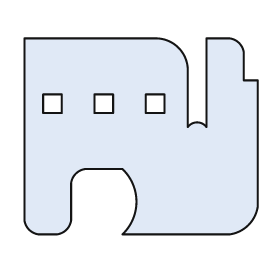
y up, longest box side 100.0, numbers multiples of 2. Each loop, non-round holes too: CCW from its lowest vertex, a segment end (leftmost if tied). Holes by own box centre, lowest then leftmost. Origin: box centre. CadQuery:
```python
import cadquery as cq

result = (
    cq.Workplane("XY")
    .moveTo(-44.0, -42.0)
    .lineTo(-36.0, -42.0)
    .threePointArc((-32.0, -40.0), (-30.0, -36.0))
    .lineTo(-30.0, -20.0)
    .threePointArc((-28.0, -16.0), (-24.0, -14.0))
    .lineTo(-8.0, -14.0)
    .threePointArc((-2.0, -28.0), (-8.0, -42.0))
    .lineTo(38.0, -42.0)
    .threePointArc((46.0, -38.0), (50.0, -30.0))
    .lineTo(50.0, 24.0)
    .lineTo(44.0, 24.0)
    .lineTo(44.0, 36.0)
    .threePointArc((42.0, 40.0), (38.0, 42.0))
    .lineTo(28.0, 42.0)
    .lineTo(28.0, 4.0)
    .threePointArc((24.0, 6.0), (20.0, 4.0))
    .lineTo(20.0, 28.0)
    .threePointArc((16.0, 38.0), (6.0, 42.0))
    .lineTo(-50.0, 42.0)
    .lineTo(-50.0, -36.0)
    .threePointArc((-48.0, -40.0), (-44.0, -42.0))
    .close()
    .moveTo(-42.0, 10.0)
    .lineTo(-34.0, 10.0)
    .lineTo(-34.0, 18.0)
    .lineTo(-42.0, 18.0)
    .close()
    .moveTo(-20.0, 10.0)
    .lineTo(-12.0, 10.0)
    .lineTo(-12.0, 18.0)
    .lineTo(-20.0, 18.0)
    .close()
    .moveTo(2.0, 10.0)
    .lineTo(10.0, 10.0)
    .lineTo(10.0, 18.0)
    .lineTo(2.0, 18.0)
    .close()
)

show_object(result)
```